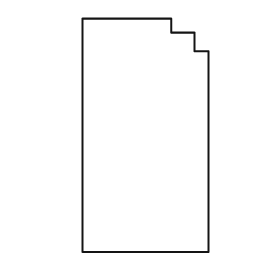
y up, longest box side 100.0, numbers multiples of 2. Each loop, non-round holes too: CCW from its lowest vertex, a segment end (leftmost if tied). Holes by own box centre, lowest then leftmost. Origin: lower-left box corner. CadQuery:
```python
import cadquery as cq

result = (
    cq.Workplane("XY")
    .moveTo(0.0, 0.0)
    .lineTo(54.0, 0.0)
    .lineTo(54.0, 86.0)
    .lineTo(48.0, 86.0)
    .lineTo(48.0, 94.0)
    .lineTo(38.0, 94.0)
    .lineTo(38.0, 100.0)
    .lineTo(0.0, 100.0)
    .close()
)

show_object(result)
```